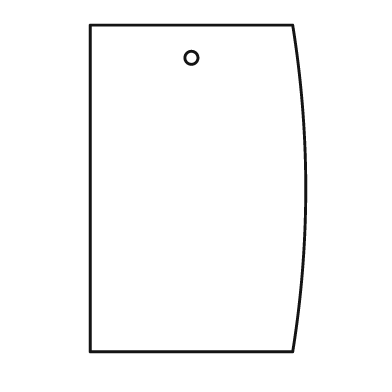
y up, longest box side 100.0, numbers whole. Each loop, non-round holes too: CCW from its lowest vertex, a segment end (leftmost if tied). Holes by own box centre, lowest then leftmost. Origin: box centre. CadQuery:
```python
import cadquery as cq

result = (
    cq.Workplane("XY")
    .moveTo(-33.0, -50.0)
    .lineTo(29.0, -50.0)
    .threePointArc((33.0, 0.0), (29.0, 50.0))
    .lineTo(-33.0, 50.0)
    .close()
    .moveTo(-2.0, 40.0)
    .circle(2.0)
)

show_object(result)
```